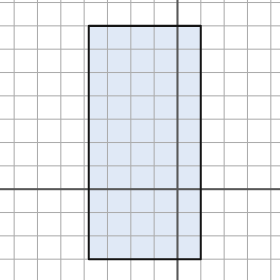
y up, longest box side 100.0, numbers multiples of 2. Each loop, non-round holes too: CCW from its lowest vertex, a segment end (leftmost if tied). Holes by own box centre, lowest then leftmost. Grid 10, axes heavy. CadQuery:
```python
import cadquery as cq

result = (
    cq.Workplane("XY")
    .moveTo(-38.0, -30.0)
    .lineTo(10.0, -30.0)
    .lineTo(10.0, 70.0)
    .lineTo(-38.0, 70.0)
    .close()
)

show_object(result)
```